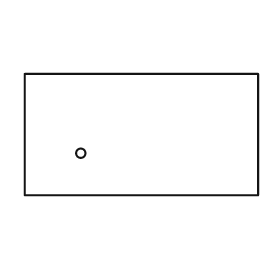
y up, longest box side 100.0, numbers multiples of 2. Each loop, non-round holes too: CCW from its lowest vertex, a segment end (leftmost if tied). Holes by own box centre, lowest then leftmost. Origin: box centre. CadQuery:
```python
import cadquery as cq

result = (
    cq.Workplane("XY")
    .moveTo(-50.0, -26.0)
    .lineTo(50.0, -26.0)
    .lineTo(50.0, 26.0)
    .lineTo(-50.0, 26.0)
    .close()
    .moveTo(-26.0, -8.0)
    .circle(2.0)
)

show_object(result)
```